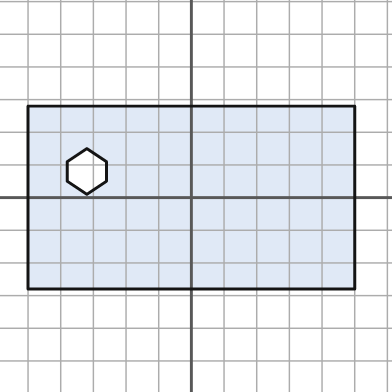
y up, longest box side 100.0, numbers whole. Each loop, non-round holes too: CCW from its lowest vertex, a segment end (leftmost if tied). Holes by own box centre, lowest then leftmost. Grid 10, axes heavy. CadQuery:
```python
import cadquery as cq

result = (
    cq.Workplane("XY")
    .moveTo(-50.0, -28.0)
    .lineTo(50.0, -28.0)
    .lineTo(50.0, 28.0)
    .lineTo(-50.0, 28.0)
    .close()
    .moveTo(-32.0, 1.0)
    .lineTo(-26.0, 5.0)
    .lineTo(-26.0, 11.0)
    .lineTo(-32.0, 15.0)
    .lineTo(-38.0, 11.0)
    .lineTo(-38.0, 5.0)
    .close()
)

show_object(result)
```